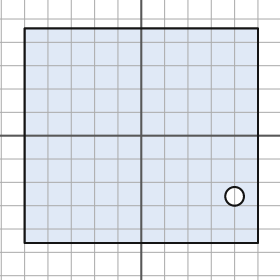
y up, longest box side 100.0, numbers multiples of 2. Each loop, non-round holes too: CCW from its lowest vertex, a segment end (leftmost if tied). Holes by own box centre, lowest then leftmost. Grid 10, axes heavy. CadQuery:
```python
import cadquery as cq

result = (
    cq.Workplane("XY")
    .moveTo(-50.0, -46.0)
    .lineTo(50.0, -46.0)
    .lineTo(50.0, 46.0)
    .lineTo(-50.0, 46.0)
    .close()
    .moveTo(40.0, -26.0)
    .circle(4.0)
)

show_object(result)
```